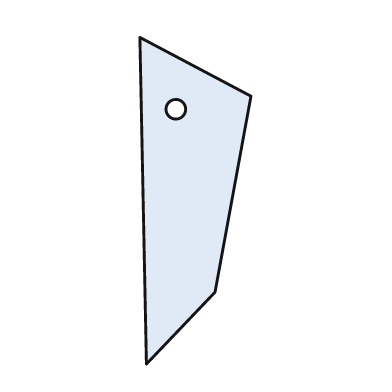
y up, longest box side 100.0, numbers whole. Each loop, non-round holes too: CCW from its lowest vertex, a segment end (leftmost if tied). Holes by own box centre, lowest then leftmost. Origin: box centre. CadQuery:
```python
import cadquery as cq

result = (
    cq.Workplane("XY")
    .moveTo(-15.0, -50.0)
    .lineTo(6.0, -28.0)
    .lineTo(17.0, 32.0)
    .lineTo(-17.0, 50.0)
    .close()
    .moveTo(-6.0, 28.0)
    .circle(3.0)
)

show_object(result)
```